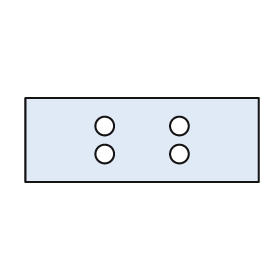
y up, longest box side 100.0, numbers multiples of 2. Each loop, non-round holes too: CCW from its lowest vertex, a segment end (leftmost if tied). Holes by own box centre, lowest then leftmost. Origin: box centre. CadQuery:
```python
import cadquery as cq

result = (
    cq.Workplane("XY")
    .moveTo(-50.0, -18.0)
    .lineTo(50.0, -18.0)
    .lineTo(50.0, 18.0)
    .lineTo(-50.0, 18.0)
    .close()
    .moveTo(-16.0, -6.0)
    .circle(4.0)
    .moveTo(16.0, -6.0)
    .circle(4.0)
    .moveTo(-16.0, 6.0)
    .circle(4.0)
    .moveTo(16.0, 6.0)
    .circle(4.0)
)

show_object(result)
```